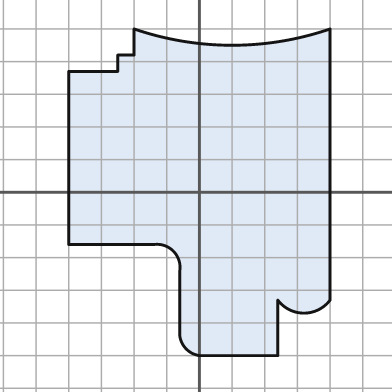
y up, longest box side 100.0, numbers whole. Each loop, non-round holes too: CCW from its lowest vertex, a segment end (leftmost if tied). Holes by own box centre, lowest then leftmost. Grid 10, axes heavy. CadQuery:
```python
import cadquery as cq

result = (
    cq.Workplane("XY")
    .moveTo(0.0, -50.0)
    .lineTo(24.0, -50.0)
    .lineTo(24.0, -33.0)
    .threePointArc((32.0, -37.0), (40.0, -33.0))
    .lineTo(40.0, 50.0)
    .threePointArc((10.0, 45.0), (-20.0, 50.0))
    .lineTo(-20.0, 42.0)
    .lineTo(-25.0, 42.0)
    .lineTo(-25.0, 37.0)
    .lineTo(-40.0, 37.0)
    .lineTo(-40.0, -16.0)
    .lineTo(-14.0, -16.0)
    .threePointArc((-8.0, -18.0), (-6.0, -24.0))
    .lineTo(-6.0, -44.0)
    .threePointArc((-4.0, -48.0), (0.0, -50.0))
    .close()
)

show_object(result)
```